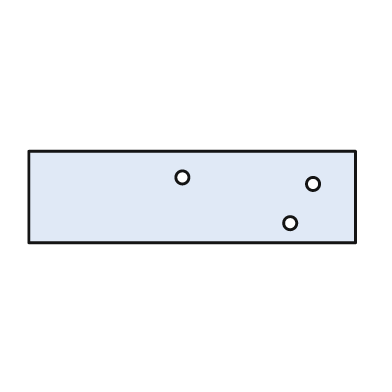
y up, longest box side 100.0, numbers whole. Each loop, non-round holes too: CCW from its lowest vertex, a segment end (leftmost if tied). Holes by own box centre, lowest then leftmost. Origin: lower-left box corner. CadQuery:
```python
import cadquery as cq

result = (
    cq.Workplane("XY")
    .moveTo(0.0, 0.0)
    .lineTo(100.0, 0.0)
    .lineTo(100.0, 28.0)
    .lineTo(0.0, 28.0)
    .close()
    .moveTo(80.0, 6.0)
    .circle(2.0)
    .moveTo(87.0, 18.0)
    .circle(2.0)
    .moveTo(47.0, 20.0)
    .circle(2.0)
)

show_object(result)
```